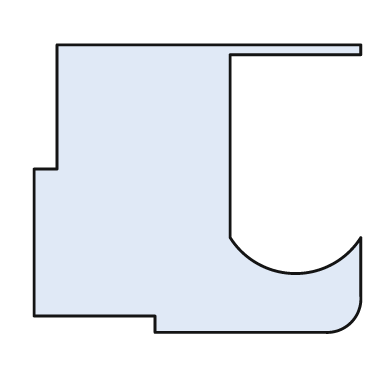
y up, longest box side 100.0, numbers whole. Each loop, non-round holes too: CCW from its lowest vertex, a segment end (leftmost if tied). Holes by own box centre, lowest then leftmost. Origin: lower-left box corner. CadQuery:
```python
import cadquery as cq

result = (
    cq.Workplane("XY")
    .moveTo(37.0, 0.0)
    .lineTo(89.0, 0.0)
    .threePointArc((97.0, 3.0), (100.0, 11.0))
    .lineTo(100.0, 29.0)
    .threePointArc((80.0, 18.0), (60.0, 29.0))
    .lineTo(60.0, 85.0)
    .lineTo(100.0, 85.0)
    .lineTo(100.0, 88.0)
    .lineTo(7.0, 88.0)
    .lineTo(7.0, 50.0)
    .lineTo(0.0, 50.0)
    .lineTo(0.0, 5.0)
    .lineTo(37.0, 5.0)
    .close()
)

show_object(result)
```